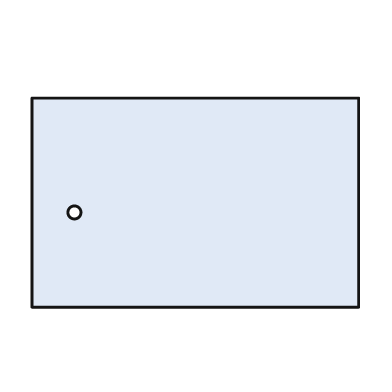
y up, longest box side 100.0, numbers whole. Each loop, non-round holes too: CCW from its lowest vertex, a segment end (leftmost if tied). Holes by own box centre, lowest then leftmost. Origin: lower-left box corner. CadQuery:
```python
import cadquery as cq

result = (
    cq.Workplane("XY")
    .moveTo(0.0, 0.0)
    .lineTo(100.0, 0.0)
    .lineTo(100.0, 64.0)
    .lineTo(0.0, 64.0)
    .close()
    .moveTo(13.0, 29.0)
    .circle(2.0)
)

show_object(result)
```